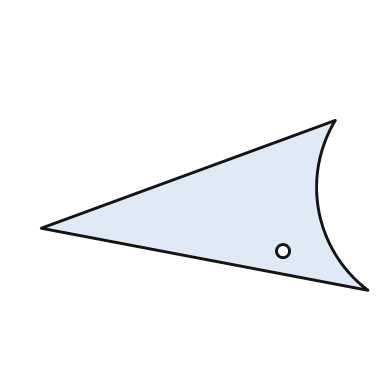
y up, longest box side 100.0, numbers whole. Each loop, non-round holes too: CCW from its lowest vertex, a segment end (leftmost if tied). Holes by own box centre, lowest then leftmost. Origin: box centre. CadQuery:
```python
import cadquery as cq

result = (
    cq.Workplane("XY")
    .moveTo(50.0, -26.0)
    .threePointArc((35.0, -2.0), (40.0, 26.0))
    .lineTo(-50.0, -7.0)
    .close()
    .moveTo(24.0, -14.0)
    .circle(2.0)
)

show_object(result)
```